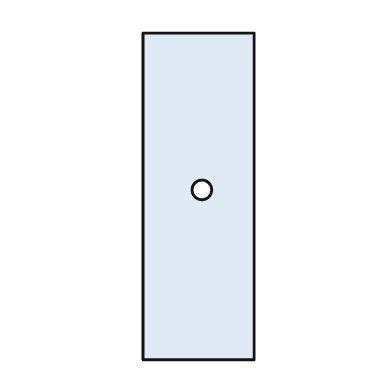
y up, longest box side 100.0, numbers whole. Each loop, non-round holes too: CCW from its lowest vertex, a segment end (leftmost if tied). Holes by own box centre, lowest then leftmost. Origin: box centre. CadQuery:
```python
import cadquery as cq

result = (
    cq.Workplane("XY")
    .moveTo(-17.0, -50.0)
    .lineTo(17.0, -50.0)
    .lineTo(17.0, 50.0)
    .lineTo(-17.0, 50.0)
    .close()
    .moveTo(1.0, 2.0)
    .circle(3.0)
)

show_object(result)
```